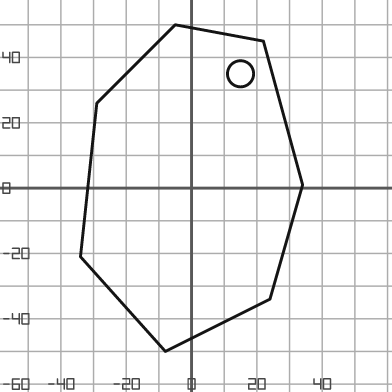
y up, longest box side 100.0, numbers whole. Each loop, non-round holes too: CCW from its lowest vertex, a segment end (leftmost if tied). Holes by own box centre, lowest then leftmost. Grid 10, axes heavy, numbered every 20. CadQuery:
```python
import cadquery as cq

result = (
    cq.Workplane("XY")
    .moveTo(-8.0, -50.0)
    .lineTo(24.0, -34.0)
    .lineTo(34.0, 1.0)
    .lineTo(22.0, 45.0)
    .lineTo(-5.0, 50.0)
    .lineTo(-29.0, 26.0)
    .lineTo(-34.0, -21.0)
    .close()
    .moveTo(15.0, 35.0)
    .circle(4.0)
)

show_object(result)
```